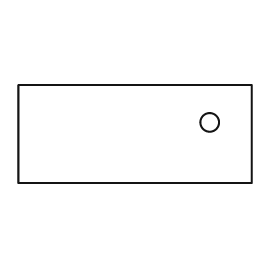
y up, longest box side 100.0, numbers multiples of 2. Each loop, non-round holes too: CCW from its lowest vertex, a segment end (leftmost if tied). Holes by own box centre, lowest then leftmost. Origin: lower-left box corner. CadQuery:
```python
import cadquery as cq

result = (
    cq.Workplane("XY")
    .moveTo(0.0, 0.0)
    .lineTo(100.0, 0.0)
    .lineTo(100.0, 42.0)
    .lineTo(0.0, 42.0)
    .close()
    .moveTo(82.0, 26.0)
    .circle(4.0)
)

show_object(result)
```